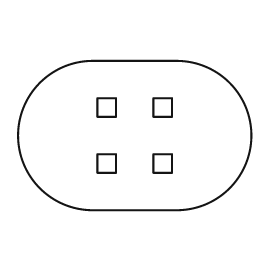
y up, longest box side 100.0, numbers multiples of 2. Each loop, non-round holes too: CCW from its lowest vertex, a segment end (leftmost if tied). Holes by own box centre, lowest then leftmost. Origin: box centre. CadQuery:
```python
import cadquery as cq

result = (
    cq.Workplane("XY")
    .moveTo(-18.0, -32.0)
    .lineTo(18.0, -32.0)
    .threePointArc((50.0, 0.0), (18.0, 32.0))
    .lineTo(-18.0, 32.0)
    .threePointArc((-50.0, 0.0), (-18.0, -32.0))
    .close()
    .moveTo(-16.0, -16.0)
    .lineTo(-8.0, -16.0)
    .lineTo(-8.0, -8.0)
    .lineTo(-16.0, -8.0)
    .close()
    .moveTo(8.0, -16.0)
    .lineTo(16.0, -16.0)
    .lineTo(16.0, -8.0)
    .lineTo(8.0, -8.0)
    .close()
    .moveTo(-16.0, 8.0)
    .lineTo(-8.0, 8.0)
    .lineTo(-8.0, 16.0)
    .lineTo(-16.0, 16.0)
    .close()
    .moveTo(8.0, 8.0)
    .lineTo(16.0, 8.0)
    .lineTo(16.0, 16.0)
    .lineTo(8.0, 16.0)
    .close()
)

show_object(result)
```